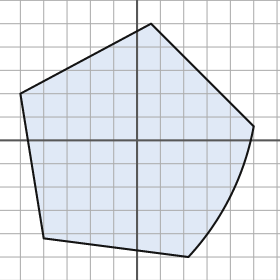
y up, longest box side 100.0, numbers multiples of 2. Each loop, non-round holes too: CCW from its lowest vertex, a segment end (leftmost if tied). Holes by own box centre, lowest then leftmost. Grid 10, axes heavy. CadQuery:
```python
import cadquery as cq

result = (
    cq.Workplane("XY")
    .moveTo(22.0, -50.0)
    .threePointArc((40.0, -24.0), (50.0, 6.0))
    .lineTo(6.0, 50.0)
    .lineTo(-50.0, 20.0)
    .lineTo(-40.0, -42.0)
    .close()
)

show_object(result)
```